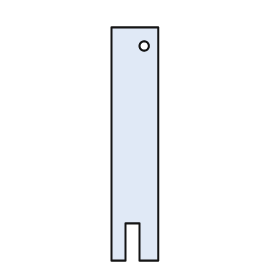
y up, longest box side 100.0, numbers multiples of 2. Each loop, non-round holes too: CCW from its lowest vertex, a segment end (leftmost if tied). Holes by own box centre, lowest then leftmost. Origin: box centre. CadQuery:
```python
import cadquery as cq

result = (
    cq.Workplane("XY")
    .moveTo(-10.0, -50.0)
    .lineTo(-4.0, -50.0)
    .lineTo(-4.0, -34.0)
    .lineTo(2.0, -34.0)
    .lineTo(2.0, -50.0)
    .lineTo(10.0, -50.0)
    .lineTo(10.0, 50.0)
    .lineTo(-10.0, 50.0)
    .close()
    .moveTo(4.0, 42.0)
    .circle(2.0)
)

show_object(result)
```